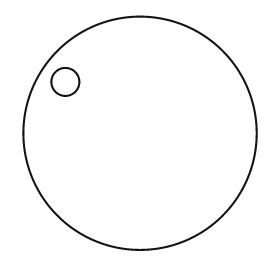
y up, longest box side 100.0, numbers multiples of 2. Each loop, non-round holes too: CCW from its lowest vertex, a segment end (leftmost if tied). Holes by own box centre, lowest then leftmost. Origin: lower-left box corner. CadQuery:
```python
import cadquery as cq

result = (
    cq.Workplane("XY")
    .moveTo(50.0, 50.0)
    .circle(50.0)
    .moveTo(18.0, 72.0)
    .circle(6.0)
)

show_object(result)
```